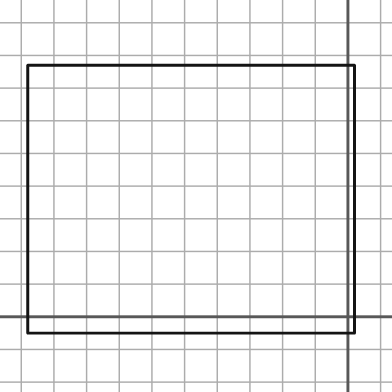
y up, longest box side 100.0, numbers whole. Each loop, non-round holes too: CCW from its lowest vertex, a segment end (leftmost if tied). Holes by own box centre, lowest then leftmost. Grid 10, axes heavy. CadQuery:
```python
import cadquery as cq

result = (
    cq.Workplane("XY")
    .moveTo(-98.0, -5.0)
    .lineTo(2.0, -5.0)
    .lineTo(2.0, 77.0)
    .lineTo(-98.0, 77.0)
    .close()
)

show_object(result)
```